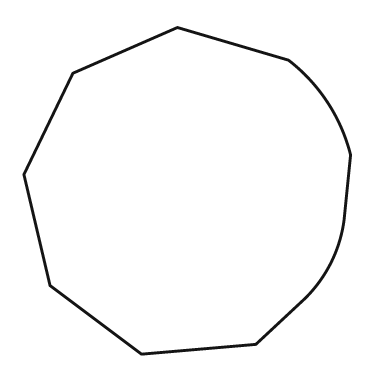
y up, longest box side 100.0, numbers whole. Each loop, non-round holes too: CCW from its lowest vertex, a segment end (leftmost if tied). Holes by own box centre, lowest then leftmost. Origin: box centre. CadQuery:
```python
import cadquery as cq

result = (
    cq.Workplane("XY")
    .moveTo(-14.0, -50.0)
    .lineTo(21.0, -47.0)
    .lineTo(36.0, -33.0)
    .threePointArc((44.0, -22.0), (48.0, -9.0))
    .lineTo(50.0, 11.0)
    .threePointArc((43.0, 27.0), (31.0, 40.0))
    .lineTo(-3.0, 50.0)
    .lineTo(-35.0, 36.0)
    .lineTo(-50.0, 5.0)
    .lineTo(-42.0, -29.0)
    .close()
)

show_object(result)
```